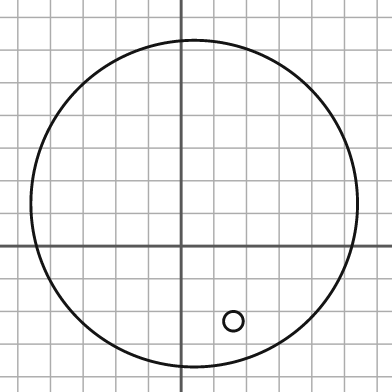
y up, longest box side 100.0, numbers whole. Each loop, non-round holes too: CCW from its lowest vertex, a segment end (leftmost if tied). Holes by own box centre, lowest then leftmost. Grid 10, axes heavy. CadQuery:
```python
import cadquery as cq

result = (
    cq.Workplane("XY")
    .moveTo(4.0, 13.0)
    .circle(50.0)
    .moveTo(16.0, -23.0)
    .circle(3.0)
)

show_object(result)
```